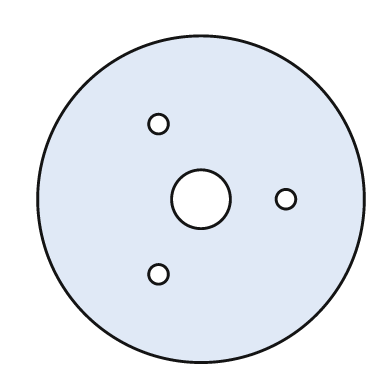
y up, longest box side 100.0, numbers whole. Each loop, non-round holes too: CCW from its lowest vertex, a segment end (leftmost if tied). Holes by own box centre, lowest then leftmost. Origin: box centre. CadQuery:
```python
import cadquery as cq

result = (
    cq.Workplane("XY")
    .moveTo(0.0, 0.0)
    .circle(50.0)
    .moveTo(-13.0, -23.0)
    .circle(3.0)
    .moveTo(0.0, 0.0)
    .circle(9.0)
    .moveTo(26.0, 0.0)
    .circle(3.0)
    .moveTo(-13.0, 23.0)
    .circle(3.0)
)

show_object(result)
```